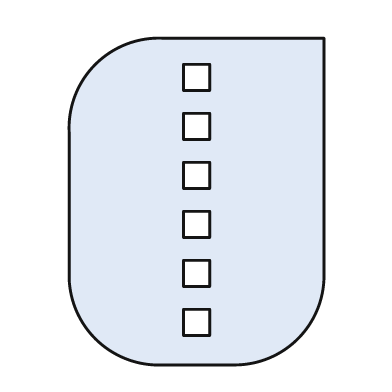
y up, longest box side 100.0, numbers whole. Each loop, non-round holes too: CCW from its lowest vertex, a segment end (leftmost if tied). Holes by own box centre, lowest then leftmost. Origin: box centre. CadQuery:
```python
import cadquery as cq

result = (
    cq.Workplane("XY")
    .moveTo(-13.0, -50.0)
    .lineTo(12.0, -50.0)
    .threePointArc((31.0, -42.0), (39.0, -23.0))
    .lineTo(39.0, 50.0)
    .lineTo(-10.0, 50.0)
    .threePointArc((-31.0, 42.0), (-39.0, 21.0))
    .lineTo(-39.0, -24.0)
    .threePointArc((-31.0, -42.0), (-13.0, -50.0))
    .close()
    .moveTo(-4.0, -41.0)
    .lineTo(4.0, -41.0)
    .lineTo(4.0, -33.0)
    .lineTo(-4.0, -33.0)
    .close()
    .moveTo(-4.0, -26.0)
    .lineTo(4.0, -26.0)
    .lineTo(4.0, -18.0)
    .lineTo(-4.0, -18.0)
    .close()
    .moveTo(-4.0, -11.0)
    .lineTo(4.0, -11.0)
    .lineTo(4.0, -3.0)
    .lineTo(-4.0, -3.0)
    .close()
    .moveTo(-4.0, 4.0)
    .lineTo(4.0, 4.0)
    .lineTo(4.0, 12.0)
    .lineTo(-4.0, 12.0)
    .close()
    .moveTo(-4.0, 19.0)
    .lineTo(4.0, 19.0)
    .lineTo(4.0, 27.0)
    .lineTo(-4.0, 27.0)
    .close()
    .moveTo(-4.0, 34.0)
    .lineTo(4.0, 34.0)
    .lineTo(4.0, 42.0)
    .lineTo(-4.0, 42.0)
    .close()
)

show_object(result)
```